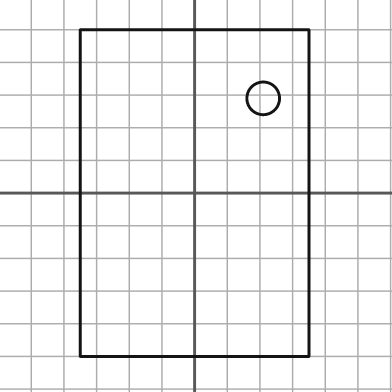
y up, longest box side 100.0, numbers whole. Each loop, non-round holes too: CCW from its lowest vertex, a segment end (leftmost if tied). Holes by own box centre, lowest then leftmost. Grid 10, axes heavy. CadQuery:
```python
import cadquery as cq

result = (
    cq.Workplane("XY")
    .moveTo(-35.0, -50.0)
    .lineTo(35.0, -50.0)
    .lineTo(35.0, 50.0)
    .lineTo(-35.0, 50.0)
    .close()
    .moveTo(21.0, 29.0)
    .circle(5.0)
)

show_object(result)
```